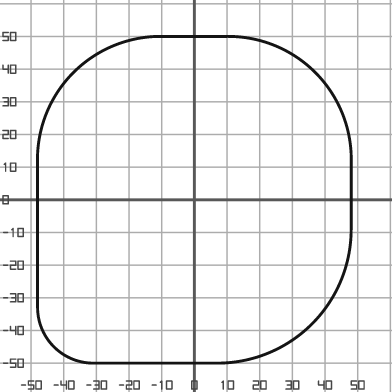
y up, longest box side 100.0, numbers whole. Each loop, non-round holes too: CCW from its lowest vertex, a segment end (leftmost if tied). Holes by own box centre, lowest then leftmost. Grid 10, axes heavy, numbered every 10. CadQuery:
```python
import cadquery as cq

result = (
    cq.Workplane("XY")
    .moveTo(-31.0, -50.0)
    .lineTo(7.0, -50.0)
    .threePointArc((36.0, -38.0), (48.0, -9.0))
    .lineTo(48.0, 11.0)
    .threePointArc((37.0, 39.0), (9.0, 50.0))
    .lineTo(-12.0, 50.0)
    .threePointArc((-37.0, 39.0), (-48.0, 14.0))
    .lineTo(-48.0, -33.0)
    .threePointArc((-43.0, -45.0), (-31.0, -50.0))
    .close()
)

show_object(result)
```